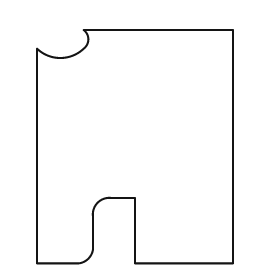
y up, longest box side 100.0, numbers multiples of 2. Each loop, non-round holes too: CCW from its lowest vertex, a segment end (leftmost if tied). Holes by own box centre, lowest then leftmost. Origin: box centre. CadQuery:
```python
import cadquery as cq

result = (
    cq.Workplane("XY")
    .moveTo(-42.0, -50.0)
    .lineTo(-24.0, -50.0)
    .threePointArc((-20.0, -48.0), (-18.0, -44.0))
    .lineTo(-18.0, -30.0)
    .threePointArc((-16.0, -24.0), (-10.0, -22.0))
    .lineTo(0.0, -22.0)
    .lineTo(0.0, -50.0)
    .lineTo(42.0, -50.0)
    .lineTo(42.0, 50.0)
    .lineTo(-22.0, 50.0)
    .threePointArc((-20.0, 46.0), (-22.0, 42.0))
    .threePointArc((-32.0, 38.0), (-42.0, 42.0))
    .close()
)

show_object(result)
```